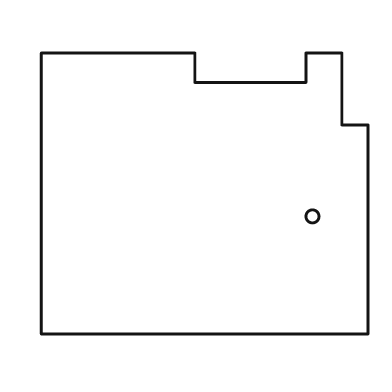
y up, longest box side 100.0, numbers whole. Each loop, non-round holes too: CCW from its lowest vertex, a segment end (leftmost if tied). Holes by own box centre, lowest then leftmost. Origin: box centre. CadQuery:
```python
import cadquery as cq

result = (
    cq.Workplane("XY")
    .moveTo(-50.0, -43.0)
    .lineTo(50.0, -43.0)
    .lineTo(50.0, 21.0)
    .lineTo(42.0, 21.0)
    .lineTo(42.0, 43.0)
    .lineTo(31.0, 43.0)
    .lineTo(31.0, 34.0)
    .lineTo(-3.0, 34.0)
    .lineTo(-3.0, 43.0)
    .lineTo(-50.0, 43.0)
    .close()
    .moveTo(33.0, -7.0)
    .circle(2.0)
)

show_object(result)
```